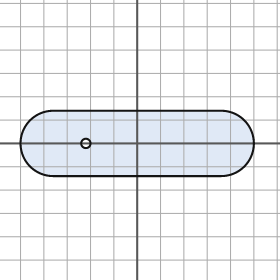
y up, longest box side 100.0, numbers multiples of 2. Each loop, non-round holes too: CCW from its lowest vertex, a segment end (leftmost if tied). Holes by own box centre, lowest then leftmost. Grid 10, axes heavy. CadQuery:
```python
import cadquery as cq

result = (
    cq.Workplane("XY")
    .moveTo(-36.0, -14.0)
    .lineTo(36.0, -14.0)
    .threePointArc((50.0, 0.0), (36.0, 14.0))
    .lineTo(-36.0, 14.0)
    .threePointArc((-50.0, 0.0), (-36.0, -14.0))
    .close()
    .moveTo(-22.0, 0.0)
    .circle(2.0)
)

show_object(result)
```